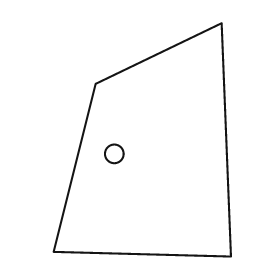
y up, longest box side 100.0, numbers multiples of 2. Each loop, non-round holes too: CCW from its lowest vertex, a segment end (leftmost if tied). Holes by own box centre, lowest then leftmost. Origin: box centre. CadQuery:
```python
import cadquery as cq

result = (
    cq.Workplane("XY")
    .moveTo(38.0, -50.0)
    .lineTo(34.0, 50.0)
    .lineTo(-20.0, 24.0)
    .lineTo(-38.0, -48.0)
    .close()
    .moveTo(-12.0, -6.0)
    .circle(4.0)
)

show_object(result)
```